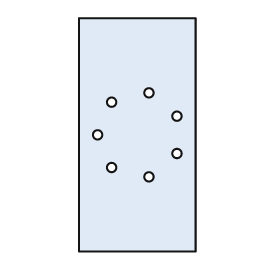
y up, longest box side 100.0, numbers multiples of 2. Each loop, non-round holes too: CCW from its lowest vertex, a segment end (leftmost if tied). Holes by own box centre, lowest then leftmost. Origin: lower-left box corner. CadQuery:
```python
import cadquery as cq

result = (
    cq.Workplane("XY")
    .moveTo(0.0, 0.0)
    .lineTo(50.0, 0.0)
    .lineTo(50.0, 100.0)
    .lineTo(0.0, 100.0)
    .close()
    .moveTo(30.0, 32.0)
    .circle(2.0)
    .moveTo(14.0, 36.0)
    .circle(2.0)
    .moveTo(42.0, 42.0)
    .circle(2.0)
    .moveTo(8.0, 50.0)
    .circle(2.0)
    .moveTo(42.0, 58.0)
    .circle(2.0)
    .moveTo(14.0, 64.0)
    .circle(2.0)
    .moveTo(30.0, 68.0)
    .circle(2.0)
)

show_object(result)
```